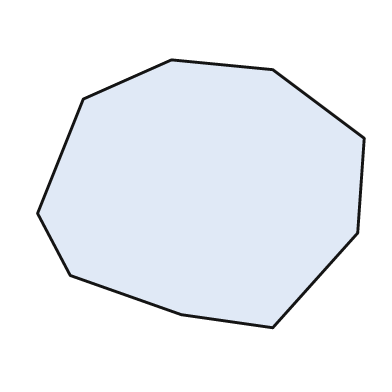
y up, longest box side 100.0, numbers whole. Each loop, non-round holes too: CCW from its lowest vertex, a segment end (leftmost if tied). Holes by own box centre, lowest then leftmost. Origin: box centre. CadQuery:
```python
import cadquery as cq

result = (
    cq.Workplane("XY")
    .moveTo(22.0, -41.0)
    .lineTo(48.0, -12.0)
    .lineTo(50.0, 17.0)
    .lineTo(22.0, 38.0)
    .lineTo(-9.0, 41.0)
    .lineTo(-36.0, 29.0)
    .lineTo(-50.0, -6.0)
    .lineTo(-40.0, -25.0)
    .lineTo(-6.0, -37.0)
    .close()
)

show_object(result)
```